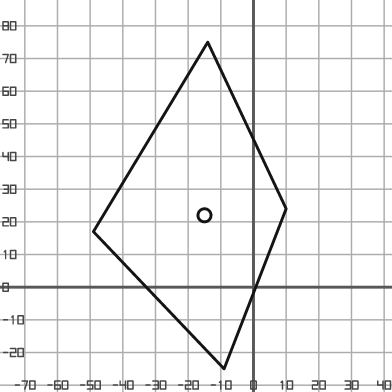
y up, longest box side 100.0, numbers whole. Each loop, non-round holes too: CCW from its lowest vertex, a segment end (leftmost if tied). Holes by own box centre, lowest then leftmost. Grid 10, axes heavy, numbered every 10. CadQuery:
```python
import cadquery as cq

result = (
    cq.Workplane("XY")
    .moveTo(-9.0, -25.0)
    .lineTo(10.0, 24.0)
    .lineTo(-14.0, 75.0)
    .lineTo(-49.0, 17.0)
    .close()
    .moveTo(-15.0, 22.0)
    .circle(2.0)
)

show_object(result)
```